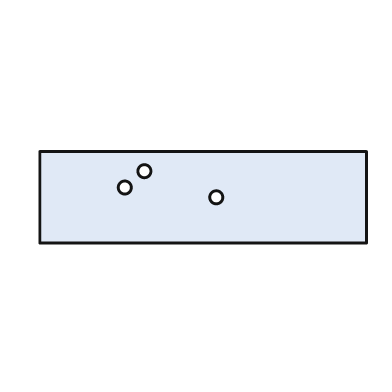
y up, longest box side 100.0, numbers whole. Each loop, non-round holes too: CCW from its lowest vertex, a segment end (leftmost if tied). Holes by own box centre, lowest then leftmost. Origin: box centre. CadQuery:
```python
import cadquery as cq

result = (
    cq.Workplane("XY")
    .moveTo(-50.0, -14.0)
    .lineTo(50.0, -14.0)
    .lineTo(50.0, 14.0)
    .lineTo(-50.0, 14.0)
    .close()
    .moveTo(4.0, 0.0)
    .circle(2.0)
    .moveTo(-24.0, 3.0)
    .circle(2.0)
    .moveTo(-18.0, 8.0)
    .circle(2.0)
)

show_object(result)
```